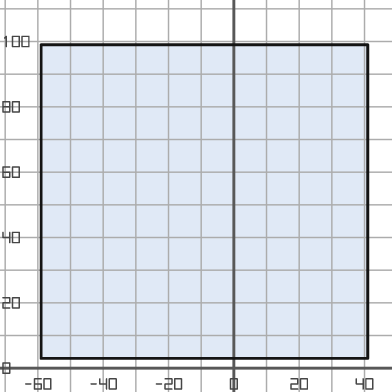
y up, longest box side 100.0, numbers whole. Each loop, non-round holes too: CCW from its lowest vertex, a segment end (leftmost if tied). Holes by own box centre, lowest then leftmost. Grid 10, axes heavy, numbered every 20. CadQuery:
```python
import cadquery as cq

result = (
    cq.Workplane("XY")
    .moveTo(-59.0, 3.0)
    .lineTo(41.0, 3.0)
    .lineTo(41.0, 99.0)
    .lineTo(-59.0, 99.0)
    .close()
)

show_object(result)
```